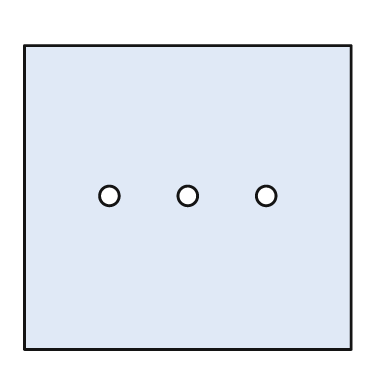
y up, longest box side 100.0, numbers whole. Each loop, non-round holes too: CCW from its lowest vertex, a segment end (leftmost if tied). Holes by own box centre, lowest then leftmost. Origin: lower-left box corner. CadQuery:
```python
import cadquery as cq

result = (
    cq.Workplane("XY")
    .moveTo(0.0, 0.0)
    .lineTo(100.0, 0.0)
    .lineTo(100.0, 93.0)
    .lineTo(0.0, 93.0)
    .close()
    .moveTo(26.0, 47.0)
    .circle(3.0)
    .moveTo(50.0, 47.0)
    .circle(3.0)
    .moveTo(74.0, 47.0)
    .circle(3.0)
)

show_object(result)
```